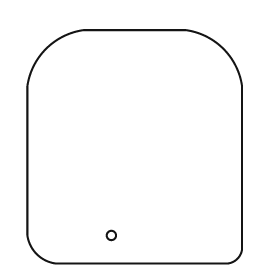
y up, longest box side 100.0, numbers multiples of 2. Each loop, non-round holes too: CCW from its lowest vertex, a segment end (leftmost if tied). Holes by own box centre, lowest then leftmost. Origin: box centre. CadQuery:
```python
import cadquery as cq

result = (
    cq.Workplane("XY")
    .moveTo(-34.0, -50.0)
    .lineTo(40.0, -50.0)
    .threePointArc((44.0, -48.0), (46.0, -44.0))
    .lineTo(46.0, 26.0)
    .threePointArc((38.0, 42.0), (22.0, 50.0))
    .lineTo(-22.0, 50.0)
    .threePointArc((-38.0, 42.0), (-46.0, 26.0))
    .lineTo(-46.0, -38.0)
    .threePointArc((-42.0, -46.0), (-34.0, -50.0))
    .close()
    .moveTo(-10.0, -38.0)
    .circle(2.0)
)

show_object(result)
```